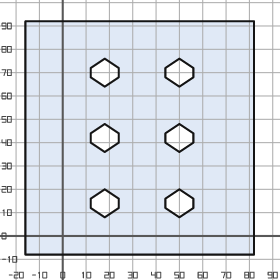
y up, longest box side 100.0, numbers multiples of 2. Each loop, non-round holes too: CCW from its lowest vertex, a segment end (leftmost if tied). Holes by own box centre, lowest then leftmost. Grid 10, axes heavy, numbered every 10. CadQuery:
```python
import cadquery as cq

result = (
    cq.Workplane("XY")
    .moveTo(-16.0, -8.0)
    .lineTo(82.0, -8.0)
    .lineTo(82.0, 92.0)
    .lineTo(-16.0, 92.0)
    .close()
    .moveTo(18.0, 8.0)
    .lineTo(24.0, 12.0)
    .lineTo(24.0, 16.0)
    .lineTo(18.0, 20.0)
    .lineTo(12.0, 16.0)
    .lineTo(12.0, 12.0)
    .close()
    .moveTo(50.0, 8.0)
    .lineTo(56.0, 12.0)
    .lineTo(56.0, 16.0)
    .lineTo(50.0, 20.0)
    .lineTo(44.0, 16.0)
    .lineTo(44.0, 12.0)
    .close()
    .moveTo(18.0, 36.0)
    .lineTo(24.0, 40.0)
    .lineTo(24.0, 44.0)
    .lineTo(18.0, 48.0)
    .lineTo(12.0, 44.0)
    .lineTo(12.0, 40.0)
    .close()
    .moveTo(50.0, 36.0)
    .lineTo(56.0, 40.0)
    .lineTo(56.0, 44.0)
    .lineTo(50.0, 48.0)
    .lineTo(44.0, 44.0)
    .lineTo(44.0, 40.0)
    .close()
    .moveTo(18.0, 64.0)
    .lineTo(24.0, 68.0)
    .lineTo(24.0, 72.0)
    .lineTo(18.0, 76.0)
    .lineTo(12.0, 72.0)
    .lineTo(12.0, 68.0)
    .close()
    .moveTo(50.0, 64.0)
    .lineTo(56.0, 68.0)
    .lineTo(56.0, 72.0)
    .lineTo(50.0, 76.0)
    .lineTo(44.0, 72.0)
    .lineTo(44.0, 68.0)
    .close()
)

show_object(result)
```